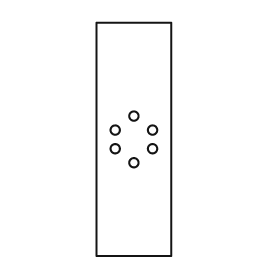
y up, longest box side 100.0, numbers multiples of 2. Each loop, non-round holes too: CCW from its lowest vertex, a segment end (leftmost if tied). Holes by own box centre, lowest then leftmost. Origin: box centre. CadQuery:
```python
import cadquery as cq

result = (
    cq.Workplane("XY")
    .moveTo(-16.0, -50.0)
    .lineTo(16.0, -50.0)
    .lineTo(16.0, 50.0)
    .lineTo(-16.0, 50.0)
    .close()
    .moveTo(0.0, -10.0)
    .circle(2.0)
    .moveTo(-8.0, -4.0)
    .circle(2.0)
    .moveTo(8.0, -4.0)
    .circle(2.0)
    .moveTo(-8.0, 4.0)
    .circle(2.0)
    .moveTo(8.0, 4.0)
    .circle(2.0)
    .moveTo(0.0, 10.0)
    .circle(2.0)
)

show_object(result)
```